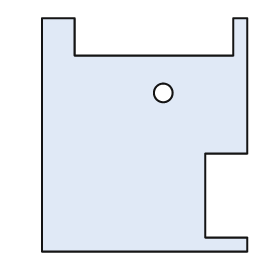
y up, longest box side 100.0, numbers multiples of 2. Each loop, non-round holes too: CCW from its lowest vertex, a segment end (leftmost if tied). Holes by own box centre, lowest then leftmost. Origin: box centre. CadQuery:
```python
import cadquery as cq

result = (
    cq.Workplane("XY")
    .moveTo(-44.0, -50.0)
    .lineTo(44.0, -50.0)
    .lineTo(44.0, -44.0)
    .lineTo(26.0, -44.0)
    .lineTo(26.0, -8.0)
    .lineTo(44.0, -8.0)
    .lineTo(44.0, 50.0)
    .lineTo(38.0, 50.0)
    .lineTo(38.0, 34.0)
    .lineTo(-30.0, 34.0)
    .lineTo(-30.0, 50.0)
    .lineTo(-44.0, 50.0)
    .close()
    .moveTo(8.0, 18.0)
    .circle(4.0)
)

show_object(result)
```